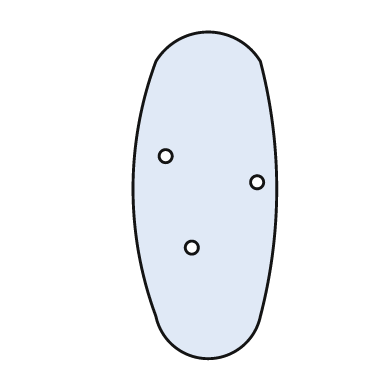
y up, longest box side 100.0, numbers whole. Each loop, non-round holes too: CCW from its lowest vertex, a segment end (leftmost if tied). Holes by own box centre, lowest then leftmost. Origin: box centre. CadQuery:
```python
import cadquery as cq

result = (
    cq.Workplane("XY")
    .moveTo(-15.0, -37.0)
    .threePointArc((1.0, -50.0), (17.0, -37.0))
    .threePointArc((22.0, 2.0), (17.0, 41.0))
    .threePointArc((1.0, 50.0), (-15.0, 41.0))
    .threePointArc((-22.0, 2.0), (-15.0, -37.0))
    .close()
    .moveTo(-4.0, -16.0)
    .circle(2.0)
    .moveTo(16.0, 4.0)
    .circle(2.0)
    .moveTo(-12.0, 12.0)
    .circle(2.0)
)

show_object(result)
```